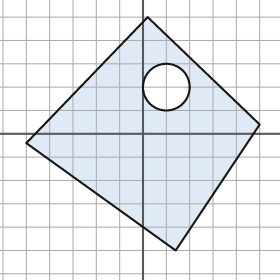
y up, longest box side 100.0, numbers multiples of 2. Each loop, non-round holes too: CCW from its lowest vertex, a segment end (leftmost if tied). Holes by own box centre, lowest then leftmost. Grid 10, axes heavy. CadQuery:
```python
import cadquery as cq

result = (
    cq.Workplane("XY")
    .moveTo(14.0, -50.0)
    .lineTo(50.0, 4.0)
    .lineTo(2.0, 50.0)
    .lineTo(-50.0, -4.0)
    .close()
    .moveTo(10.0, 20.0)
    .circle(10.0)
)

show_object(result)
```